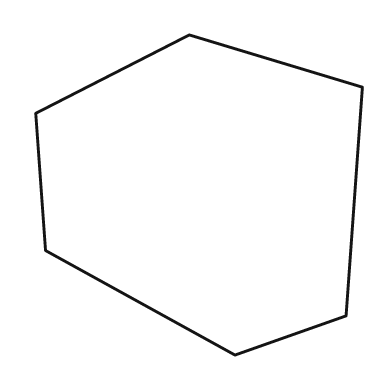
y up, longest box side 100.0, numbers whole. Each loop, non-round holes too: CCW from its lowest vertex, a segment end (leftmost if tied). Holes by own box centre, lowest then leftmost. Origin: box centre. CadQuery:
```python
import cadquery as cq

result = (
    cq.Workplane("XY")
    .moveTo(11.0, -49.0)
    .lineTo(45.0, -37.0)
    .lineTo(50.0, 33.0)
    .lineTo(-3.0, 49.0)
    .lineTo(-50.0, 25.0)
    .lineTo(-47.0, -17.0)
    .close()
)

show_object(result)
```